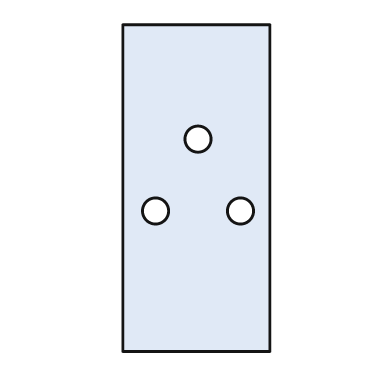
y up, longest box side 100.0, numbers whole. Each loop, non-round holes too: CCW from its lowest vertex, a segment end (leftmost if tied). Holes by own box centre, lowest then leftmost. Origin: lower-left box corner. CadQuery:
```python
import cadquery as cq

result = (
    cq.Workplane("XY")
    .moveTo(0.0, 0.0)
    .lineTo(45.0, 0.0)
    .lineTo(45.0, 100.0)
    .lineTo(0.0, 100.0)
    .close()
    .moveTo(10.0, 43.0)
    .circle(4.0)
    .moveTo(36.0, 43.0)
    .circle(4.0)
    .moveTo(23.0, 65.0)
    .circle(4.0)
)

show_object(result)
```